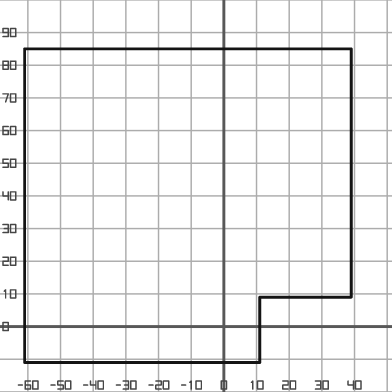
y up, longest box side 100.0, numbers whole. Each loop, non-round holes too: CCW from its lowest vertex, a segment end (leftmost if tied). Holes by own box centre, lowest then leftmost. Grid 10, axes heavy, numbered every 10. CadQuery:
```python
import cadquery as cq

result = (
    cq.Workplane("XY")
    .moveTo(-61.0, -11.0)
    .lineTo(11.0, -11.0)
    .lineTo(11.0, 9.0)
    .lineTo(39.0, 9.0)
    .lineTo(39.0, 85.0)
    .lineTo(-61.0, 85.0)
    .close()
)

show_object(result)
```